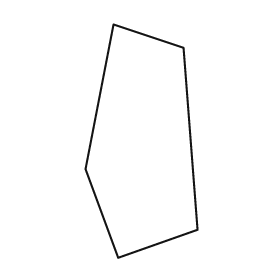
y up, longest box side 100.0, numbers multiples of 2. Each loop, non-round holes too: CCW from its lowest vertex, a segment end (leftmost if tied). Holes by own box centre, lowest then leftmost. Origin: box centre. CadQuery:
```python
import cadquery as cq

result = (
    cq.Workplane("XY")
    .moveTo(-10.0, -50.0)
    .lineTo(24.0, -38.0)
    .lineTo(18.0, 40.0)
    .lineTo(-12.0, 50.0)
    .lineTo(-24.0, -12.0)
    .close()
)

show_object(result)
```